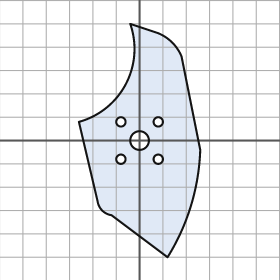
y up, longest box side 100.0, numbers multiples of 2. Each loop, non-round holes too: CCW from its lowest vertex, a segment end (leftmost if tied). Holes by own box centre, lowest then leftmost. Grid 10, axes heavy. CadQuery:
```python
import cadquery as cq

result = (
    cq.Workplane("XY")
    .moveTo(12.0, -50.0)
    .threePointArc((22.0, -28.0), (26.0, -4.0))
    .lineTo(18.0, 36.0)
    .threePointArc((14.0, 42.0), (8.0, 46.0))
    .lineTo(-4.0, 50.0)
    .threePointArc((-6.0, 24.0), (-26.0, 8.0))
    .lineTo(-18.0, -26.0)
    .threePointArc((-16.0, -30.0), (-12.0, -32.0))
    .close()
    .moveTo(-8.0, -8.0)
    .circle(2.0)
    .moveTo(8.0, -8.0)
    .circle(2.0)
    .moveTo(0.0, 0.0)
    .circle(4.0)
    .moveTo(-8.0, 8.0)
    .circle(2.0)
    .moveTo(8.0, 8.0)
    .circle(2.0)
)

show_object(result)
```